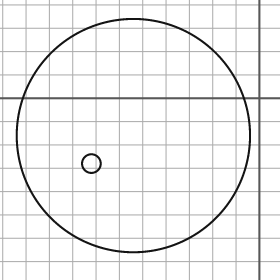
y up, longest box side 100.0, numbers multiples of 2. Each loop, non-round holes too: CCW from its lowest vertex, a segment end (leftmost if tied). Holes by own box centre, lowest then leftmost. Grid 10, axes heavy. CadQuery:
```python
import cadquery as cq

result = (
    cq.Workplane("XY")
    .moveTo(-54.0, -16.0)
    .circle(50.0)
    .moveTo(-72.0, -28.0)
    .circle(4.0)
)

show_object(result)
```